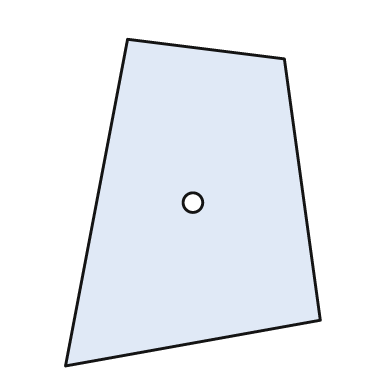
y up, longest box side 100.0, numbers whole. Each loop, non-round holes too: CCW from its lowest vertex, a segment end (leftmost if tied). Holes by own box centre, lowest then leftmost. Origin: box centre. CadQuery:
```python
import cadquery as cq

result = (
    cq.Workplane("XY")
    .moveTo(-39.0, -50.0)
    .lineTo(39.0, -36.0)
    .lineTo(28.0, 44.0)
    .lineTo(-20.0, 50.0)
    .close()
    .moveTo(0.0, 0.0)
    .circle(3.0)
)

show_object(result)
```